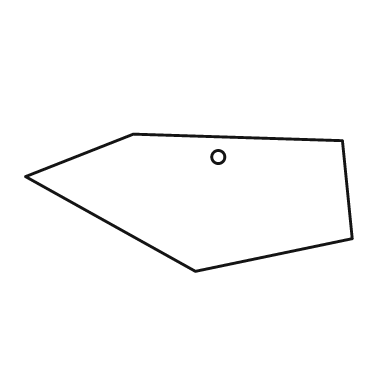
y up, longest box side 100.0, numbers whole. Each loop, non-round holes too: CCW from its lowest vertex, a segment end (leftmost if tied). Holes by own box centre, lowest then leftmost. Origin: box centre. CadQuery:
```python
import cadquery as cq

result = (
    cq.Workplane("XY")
    .moveTo(2.0, -21.0)
    .lineTo(50.0, -11.0)
    .lineTo(47.0, 19.0)
    .lineTo(-17.0, 21.0)
    .lineTo(-50.0, 8.0)
    .close()
    .moveTo(9.0, 14.0)
    .circle(2.0)
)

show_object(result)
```